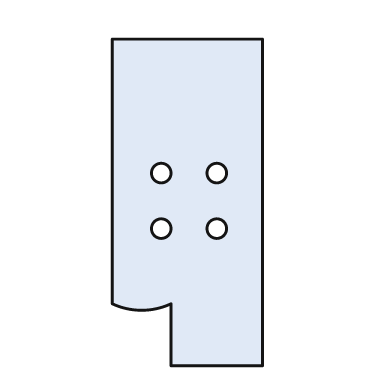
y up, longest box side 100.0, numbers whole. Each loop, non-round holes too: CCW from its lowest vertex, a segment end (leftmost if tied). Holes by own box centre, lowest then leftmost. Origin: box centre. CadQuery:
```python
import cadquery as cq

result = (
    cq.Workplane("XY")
    .moveTo(-5.0, -50.0)
    .lineTo(23.0, -50.0)
    .lineTo(23.0, 50.0)
    .lineTo(-23.0, 50.0)
    .lineTo(-23.0, -31.0)
    .threePointArc((-14.0, -33.0), (-5.0, -31.0))
    .close()
    .moveTo(-8.0, -8.0)
    .circle(3.0)
    .moveTo(9.0, -8.0)
    .circle(3.0)
    .moveTo(-8.0, 9.0)
    .circle(3.0)
    .moveTo(9.0, 9.0)
    .circle(3.0)
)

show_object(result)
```